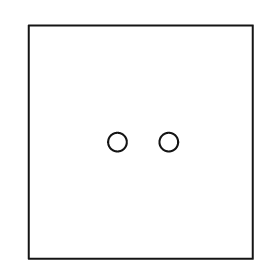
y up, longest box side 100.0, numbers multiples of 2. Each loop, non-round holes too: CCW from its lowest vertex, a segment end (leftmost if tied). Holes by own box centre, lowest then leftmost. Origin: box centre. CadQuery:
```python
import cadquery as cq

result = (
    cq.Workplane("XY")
    .moveTo(-48.0, -50.0)
    .lineTo(48.0, -50.0)
    .lineTo(48.0, 50.0)
    .lineTo(-48.0, 50.0)
    .close()
    .moveTo(-10.0, 0.0)
    .circle(4.0)
    .moveTo(12.0, 0.0)
    .circle(4.0)
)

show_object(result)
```